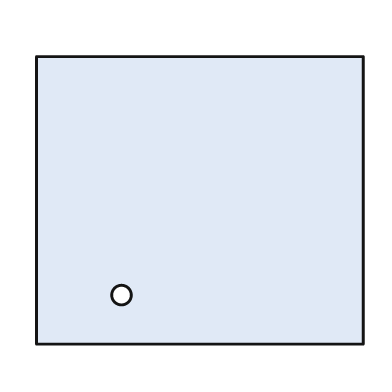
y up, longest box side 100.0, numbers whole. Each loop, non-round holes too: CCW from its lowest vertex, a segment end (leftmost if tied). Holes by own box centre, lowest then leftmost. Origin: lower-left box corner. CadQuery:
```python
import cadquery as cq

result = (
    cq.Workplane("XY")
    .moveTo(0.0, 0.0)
    .lineTo(100.0, 0.0)
    .lineTo(100.0, 88.0)
    .lineTo(0.0, 88.0)
    .close()
    .moveTo(26.0, 15.0)
    .circle(3.0)
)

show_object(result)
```